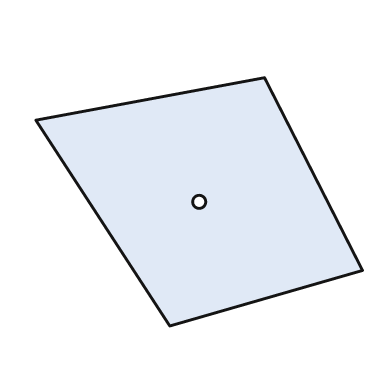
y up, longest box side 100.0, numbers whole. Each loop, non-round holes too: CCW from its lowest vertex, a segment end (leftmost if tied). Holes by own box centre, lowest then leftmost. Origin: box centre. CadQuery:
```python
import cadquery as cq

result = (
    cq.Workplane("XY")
    .moveTo(-9.0, -38.0)
    .lineTo(50.0, -21.0)
    .lineTo(20.0, 38.0)
    .lineTo(-50.0, 25.0)
    .close()
    .moveTo(0.0, 0.0)
    .circle(2.0)
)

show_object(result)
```